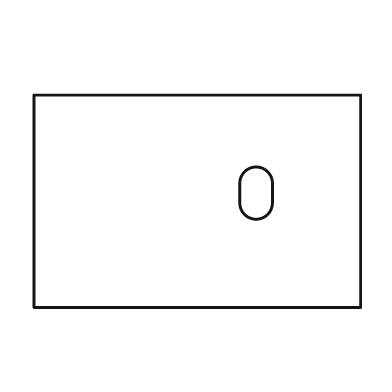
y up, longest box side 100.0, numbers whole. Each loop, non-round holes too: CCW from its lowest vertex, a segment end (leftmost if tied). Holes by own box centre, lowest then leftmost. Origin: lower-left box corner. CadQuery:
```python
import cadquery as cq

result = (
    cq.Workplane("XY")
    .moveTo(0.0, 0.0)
    .lineTo(100.0, 0.0)
    .lineTo(100.0, 65.0)
    .lineTo(0.0, 65.0)
    .close()
    .moveTo(63.0, 32.0)
    .threePointArc((68.0, 27.0), (73.0, 32.0))
    .lineTo(73.0, 38.0)
    .threePointArc((68.0, 43.0), (63.0, 38.0))
    .close()
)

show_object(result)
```